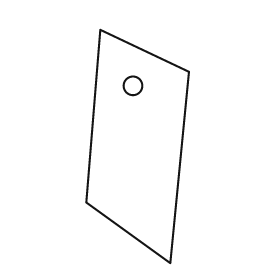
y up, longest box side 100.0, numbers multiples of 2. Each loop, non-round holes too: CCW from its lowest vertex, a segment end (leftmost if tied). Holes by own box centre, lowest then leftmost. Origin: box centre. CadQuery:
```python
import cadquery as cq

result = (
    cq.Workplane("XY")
    .moveTo(14.0, -50.0)
    .lineTo(22.0, 32.0)
    .lineTo(-16.0, 50.0)
    .lineTo(-22.0, -24.0)
    .close()
    .moveTo(-2.0, 26.0)
    .circle(4.0)
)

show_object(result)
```